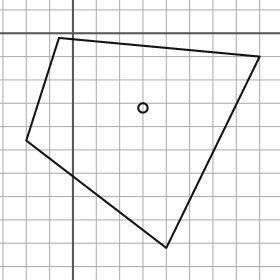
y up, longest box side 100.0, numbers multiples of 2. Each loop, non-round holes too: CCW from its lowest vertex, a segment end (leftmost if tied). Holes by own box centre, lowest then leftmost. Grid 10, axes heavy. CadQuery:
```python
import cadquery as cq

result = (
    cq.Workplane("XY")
    .moveTo(40.0, -92.0)
    .lineTo(80.0, -10.0)
    .lineTo(-6.0, -2.0)
    .lineTo(-20.0, -46.0)
    .close()
    .moveTo(30.0, -32.0)
    .circle(2.0)
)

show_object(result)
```